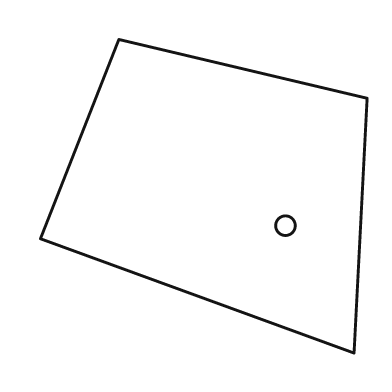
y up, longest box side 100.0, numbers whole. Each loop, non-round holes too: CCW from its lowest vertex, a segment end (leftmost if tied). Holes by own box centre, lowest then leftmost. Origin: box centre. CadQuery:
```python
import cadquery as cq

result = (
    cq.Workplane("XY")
    .moveTo(46.0, -48.0)
    .lineTo(50.0, 30.0)
    .lineTo(-26.0, 48.0)
    .lineTo(-50.0, -13.0)
    .close()
    .moveTo(25.0, -9.0)
    .circle(3.0)
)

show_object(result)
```